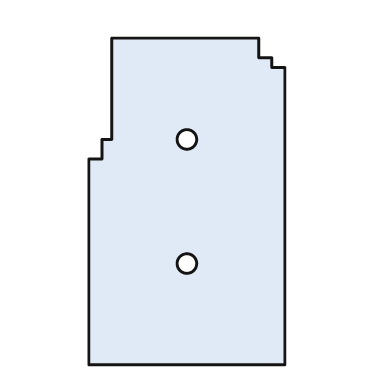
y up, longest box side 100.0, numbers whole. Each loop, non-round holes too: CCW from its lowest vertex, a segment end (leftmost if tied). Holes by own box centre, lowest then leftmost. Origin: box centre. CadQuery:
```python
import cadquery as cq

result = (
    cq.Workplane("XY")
    .moveTo(-30.0, -50.0)
    .lineTo(30.0, -50.0)
    .lineTo(30.0, 41.0)
    .lineTo(26.0, 41.0)
    .lineTo(26.0, 44.0)
    .lineTo(22.0, 44.0)
    .lineTo(22.0, 50.0)
    .lineTo(-23.0, 50.0)
    .lineTo(-23.0, 19.0)
    .lineTo(-26.0, 19.0)
    .lineTo(-26.0, 13.0)
    .lineTo(-30.0, 13.0)
    .close()
    .moveTo(0.0, -19.0)
    .circle(3.0)
    .moveTo(0.0, 19.0)
    .circle(3.0)
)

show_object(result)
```